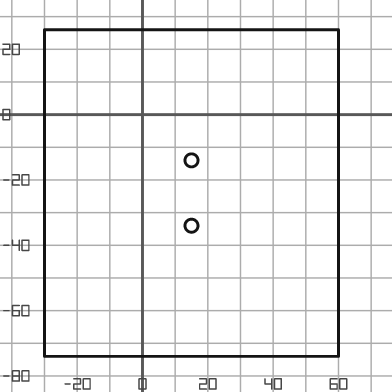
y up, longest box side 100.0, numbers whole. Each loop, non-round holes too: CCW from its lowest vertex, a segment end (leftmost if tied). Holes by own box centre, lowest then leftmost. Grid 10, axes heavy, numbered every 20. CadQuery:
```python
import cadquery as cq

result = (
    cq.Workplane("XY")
    .moveTo(-30.0, -74.0)
    .lineTo(60.0, -74.0)
    .lineTo(60.0, 26.0)
    .lineTo(-30.0, 26.0)
    .close()
    .moveTo(15.0, -34.0)
    .circle(2.0)
    .moveTo(15.0, -14.0)
    .circle(2.0)
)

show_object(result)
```